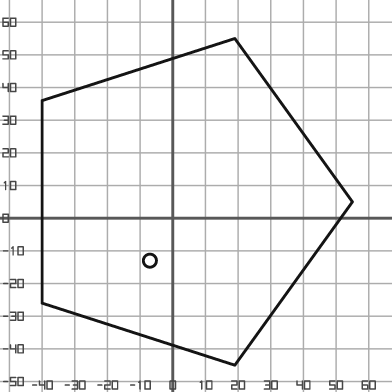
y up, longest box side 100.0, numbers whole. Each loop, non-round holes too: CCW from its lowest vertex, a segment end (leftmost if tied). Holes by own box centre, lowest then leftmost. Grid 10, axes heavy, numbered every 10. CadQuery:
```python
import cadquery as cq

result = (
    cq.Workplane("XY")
    .moveTo(19.0, -45.0)
    .lineTo(55.0, 5.0)
    .lineTo(19.0, 55.0)
    .lineTo(-40.0, 36.0)
    .lineTo(-40.0, -26.0)
    .close()
    .moveTo(-7.0, -13.0)
    .circle(2.0)
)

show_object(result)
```